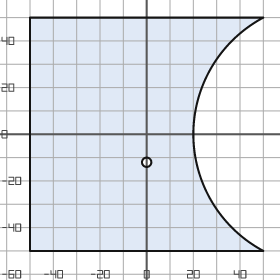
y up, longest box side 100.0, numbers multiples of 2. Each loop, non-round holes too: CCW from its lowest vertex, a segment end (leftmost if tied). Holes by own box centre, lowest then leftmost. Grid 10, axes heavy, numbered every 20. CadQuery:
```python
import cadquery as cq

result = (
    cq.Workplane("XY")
    .moveTo(-50.0, -50.0)
    .lineTo(50.0, -50.0)
    .threePointArc((20.0, 0.0), (50.0, 50.0))
    .lineTo(-50.0, 50.0)
    .close()
    .moveTo(0.0, -12.0)
    .circle(2.0)
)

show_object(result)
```